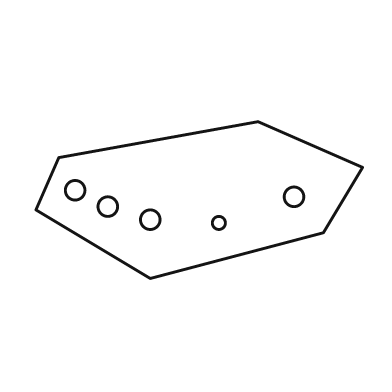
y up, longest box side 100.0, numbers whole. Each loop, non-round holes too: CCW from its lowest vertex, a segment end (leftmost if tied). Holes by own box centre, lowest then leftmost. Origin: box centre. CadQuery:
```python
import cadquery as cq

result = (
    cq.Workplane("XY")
    .moveTo(-15.0, -24.0)
    .lineTo(38.0, -10.0)
    .lineTo(50.0, 10.0)
    .lineTo(18.0, 24.0)
    .lineTo(-43.0, 13.0)
    .lineTo(-50.0, -3.0)
    .close()
    .moveTo(6.0, -7.0)
    .circle(2.0)
    .moveTo(-15.0, -6.0)
    .circle(3.0)
    .moveTo(-28.0, -2.0)
    .circle(3.0)
    .moveTo(29.0, 1.0)
    .circle(3.0)
    .moveTo(-38.0, 3.0)
    .circle(3.0)
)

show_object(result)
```